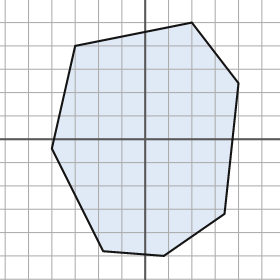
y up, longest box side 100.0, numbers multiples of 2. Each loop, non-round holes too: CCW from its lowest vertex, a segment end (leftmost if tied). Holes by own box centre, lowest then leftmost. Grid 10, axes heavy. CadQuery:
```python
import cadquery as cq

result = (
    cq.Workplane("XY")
    .moveTo(8.0, -50.0)
    .lineTo(34.0, -32.0)
    .lineTo(40.0, 24.0)
    .lineTo(20.0, 50.0)
    .lineTo(-30.0, 40.0)
    .lineTo(-40.0, -4.0)
    .lineTo(-18.0, -48.0)
    .close()
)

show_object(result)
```